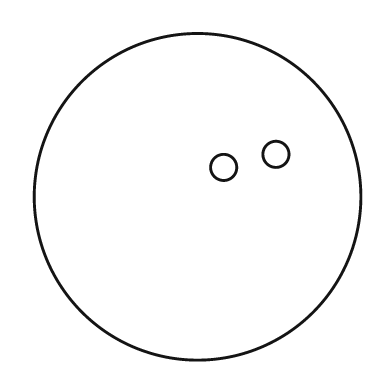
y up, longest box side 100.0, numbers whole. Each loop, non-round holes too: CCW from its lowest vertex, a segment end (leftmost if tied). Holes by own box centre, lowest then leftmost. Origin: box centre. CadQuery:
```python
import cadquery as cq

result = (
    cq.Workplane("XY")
    .moveTo(0.0, 0.0)
    .circle(50.0)
    .moveTo(8.0, 9.0)
    .circle(4.0)
    .moveTo(24.0, 13.0)
    .circle(4.0)
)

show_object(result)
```